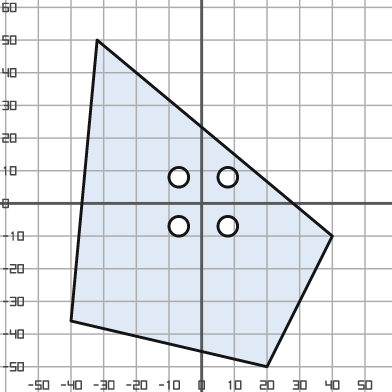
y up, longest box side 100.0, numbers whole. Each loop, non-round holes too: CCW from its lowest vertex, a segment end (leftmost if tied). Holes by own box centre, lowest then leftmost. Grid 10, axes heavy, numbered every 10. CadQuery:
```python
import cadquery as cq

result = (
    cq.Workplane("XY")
    .moveTo(20.0, -50.0)
    .lineTo(40.0, -10.0)
    .lineTo(-32.0, 50.0)
    .lineTo(-40.0, -36.0)
    .close()
    .moveTo(-7.0, -7.0)
    .circle(3.0)
    .moveTo(8.0, -7.0)
    .circle(3.0)
    .moveTo(-7.0, 8.0)
    .circle(3.0)
    .moveTo(8.0, 8.0)
    .circle(3.0)
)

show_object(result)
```